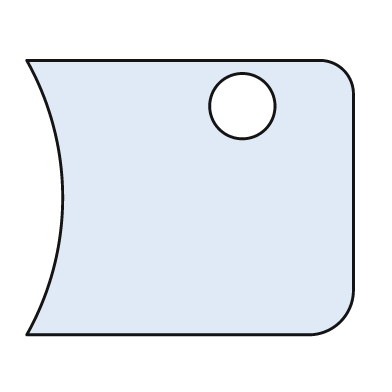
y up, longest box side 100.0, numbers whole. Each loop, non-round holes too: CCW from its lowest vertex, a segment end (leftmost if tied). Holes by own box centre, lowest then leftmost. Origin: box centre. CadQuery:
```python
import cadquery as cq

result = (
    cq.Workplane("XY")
    .moveTo(-50.0, -42.0)
    .lineTo(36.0, -42.0)
    .threePointArc((46.0, -38.0), (50.0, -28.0))
    .lineTo(50.0, 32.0)
    .threePointArc((47.0, 39.0), (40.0, 42.0))
    .lineTo(-50.0, 42.0)
    .threePointArc((-39.0, 0.0), (-50.0, -42.0))
    .close()
    .moveTo(16.0, 28.0)
    .circle(10.0)
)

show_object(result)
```